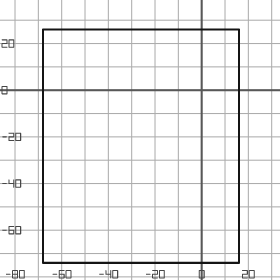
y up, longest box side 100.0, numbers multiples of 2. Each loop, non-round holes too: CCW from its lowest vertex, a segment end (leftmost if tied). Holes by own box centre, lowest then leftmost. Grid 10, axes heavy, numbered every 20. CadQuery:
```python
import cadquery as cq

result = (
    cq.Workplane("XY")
    .moveTo(-68.0, -74.0)
    .lineTo(16.0, -74.0)
    .lineTo(16.0, 26.0)
    .lineTo(-68.0, 26.0)
    .close()
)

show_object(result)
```